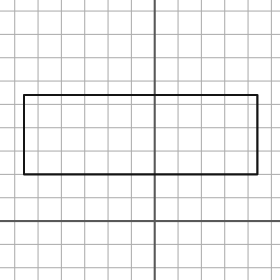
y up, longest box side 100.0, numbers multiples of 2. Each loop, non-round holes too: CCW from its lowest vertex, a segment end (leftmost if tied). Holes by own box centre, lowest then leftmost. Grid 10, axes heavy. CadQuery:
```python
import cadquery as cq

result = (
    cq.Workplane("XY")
    .moveTo(-56.0, 20.0)
    .lineTo(44.0, 20.0)
    .lineTo(44.0, 54.0)
    .lineTo(-56.0, 54.0)
    .close()
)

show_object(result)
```